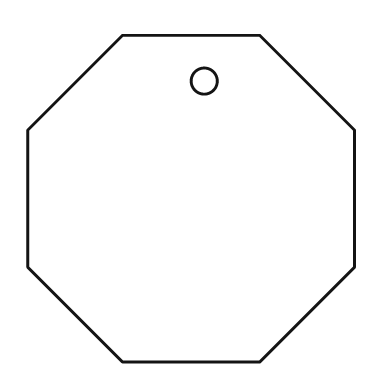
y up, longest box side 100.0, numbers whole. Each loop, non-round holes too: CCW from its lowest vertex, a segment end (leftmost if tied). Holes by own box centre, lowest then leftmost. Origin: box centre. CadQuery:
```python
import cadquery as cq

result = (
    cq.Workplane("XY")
    .moveTo(-21.0, -50.0)
    .lineTo(21.0, -50.0)
    .lineTo(50.0, -21.0)
    .lineTo(50.0, 21.0)
    .lineTo(21.0, 50.0)
    .lineTo(-21.0, 50.0)
    .lineTo(-50.0, 21.0)
    .lineTo(-50.0, -21.0)
    .close()
    .moveTo(4.0, 36.0)
    .circle(4.0)
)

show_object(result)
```